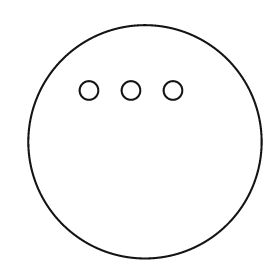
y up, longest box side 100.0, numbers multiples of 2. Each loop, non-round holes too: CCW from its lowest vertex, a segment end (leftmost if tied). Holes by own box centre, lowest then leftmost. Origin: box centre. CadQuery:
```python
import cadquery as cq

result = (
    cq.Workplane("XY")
    .moveTo(0.0, 0.0)
    .circle(50.0)
    .moveTo(-24.0, 22.0)
    .circle(4.0)
    .moveTo(-6.0, 22.0)
    .circle(4.0)
    .moveTo(12.0, 22.0)
    .circle(4.0)
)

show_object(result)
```